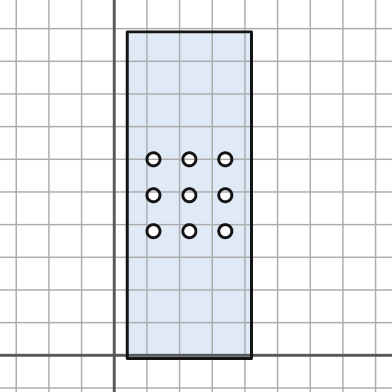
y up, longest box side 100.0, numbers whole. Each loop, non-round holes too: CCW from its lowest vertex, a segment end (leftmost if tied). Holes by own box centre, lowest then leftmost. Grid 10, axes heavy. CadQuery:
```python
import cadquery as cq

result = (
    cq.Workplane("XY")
    .moveTo(4.0, -1.0)
    .lineTo(42.0, -1.0)
    .lineTo(42.0, 99.0)
    .lineTo(4.0, 99.0)
    .close()
    .moveTo(12.0, 38.0)
    .circle(2.0)
    .moveTo(23.0, 38.0)
    .circle(2.0)
    .moveTo(34.0, 38.0)
    .circle(2.0)
    .moveTo(12.0, 49.0)
    .circle(2.0)
    .moveTo(23.0, 49.0)
    .circle(2.0)
    .moveTo(34.0, 49.0)
    .circle(2.0)
    .moveTo(12.0, 60.0)
    .circle(2.0)
    .moveTo(23.0, 60.0)
    .circle(2.0)
    .moveTo(34.0, 60.0)
    .circle(2.0)
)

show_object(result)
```